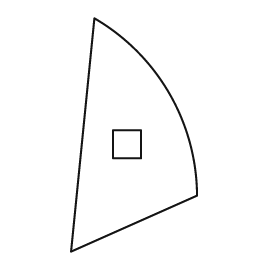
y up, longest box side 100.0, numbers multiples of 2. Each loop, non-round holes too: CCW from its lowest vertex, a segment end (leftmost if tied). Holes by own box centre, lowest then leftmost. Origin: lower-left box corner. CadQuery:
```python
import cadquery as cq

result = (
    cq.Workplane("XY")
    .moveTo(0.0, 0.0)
    .lineTo(54.0, 24.0)
    .threePointArc((42.0, 68.0), (10.0, 100.0))
    .close()
    .moveTo(18.0, 40.0)
    .lineTo(30.0, 40.0)
    .lineTo(30.0, 52.0)
    .lineTo(18.0, 52.0)
    .close()
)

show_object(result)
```